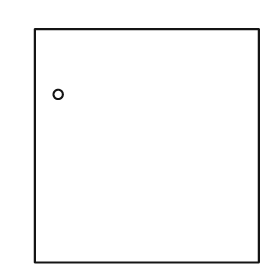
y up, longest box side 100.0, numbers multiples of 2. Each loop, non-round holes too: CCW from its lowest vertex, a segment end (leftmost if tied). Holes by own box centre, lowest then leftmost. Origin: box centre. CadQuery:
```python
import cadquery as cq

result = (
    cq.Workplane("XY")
    .moveTo(-48.0, -50.0)
    .lineTo(48.0, -50.0)
    .lineTo(48.0, 50.0)
    .lineTo(-48.0, 50.0)
    .close()
    .moveTo(-38.0, 22.0)
    .circle(2.0)
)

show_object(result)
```